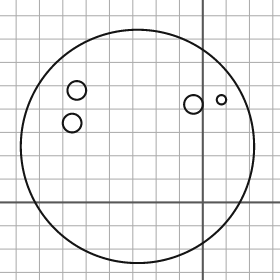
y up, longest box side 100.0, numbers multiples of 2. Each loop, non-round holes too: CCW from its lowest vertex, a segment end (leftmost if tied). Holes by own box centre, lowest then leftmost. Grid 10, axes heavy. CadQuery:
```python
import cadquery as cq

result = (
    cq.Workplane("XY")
    .moveTo(-28.0, 24.0)
    .circle(50.0)
    .moveTo(-56.0, 34.0)
    .circle(4.0)
    .moveTo(-4.0, 42.0)
    .circle(4.0)
    .moveTo(8.0, 44.0)
    .circle(2.0)
    .moveTo(-54.0, 48.0)
    .circle(4.0)
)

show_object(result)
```